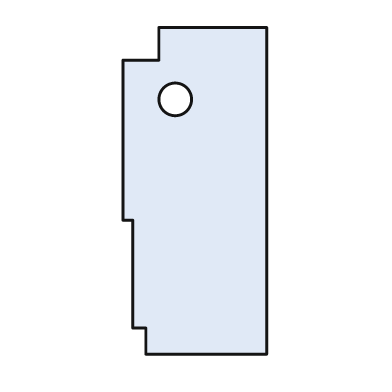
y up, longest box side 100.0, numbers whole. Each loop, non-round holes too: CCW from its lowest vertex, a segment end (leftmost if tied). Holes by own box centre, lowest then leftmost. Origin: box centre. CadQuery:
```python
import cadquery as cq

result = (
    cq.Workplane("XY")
    .moveTo(-15.0, -50.0)
    .lineTo(22.0, -50.0)
    .lineTo(22.0, 50.0)
    .lineTo(-11.0, 50.0)
    .lineTo(-11.0, 40.0)
    .lineTo(-22.0, 40.0)
    .lineTo(-22.0, -9.0)
    .lineTo(-19.0, -9.0)
    .lineTo(-19.0, -42.0)
    .lineTo(-15.0, -42.0)
    .close()
    .moveTo(-6.0, 28.0)
    .circle(5.0)
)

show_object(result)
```